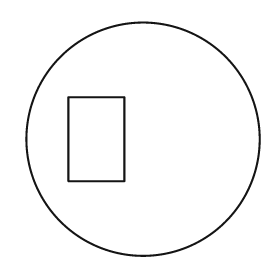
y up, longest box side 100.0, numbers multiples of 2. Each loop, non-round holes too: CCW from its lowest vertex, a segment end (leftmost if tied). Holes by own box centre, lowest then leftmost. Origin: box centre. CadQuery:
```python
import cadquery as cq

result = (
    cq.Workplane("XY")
    .moveTo(0.0, 0.0)
    .circle(50.0)
    .moveTo(-32.0, -18.0)
    .lineTo(-8.0, -18.0)
    .lineTo(-8.0, 18.0)
    .lineTo(-32.0, 18.0)
    .close()
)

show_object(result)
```